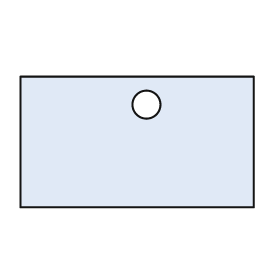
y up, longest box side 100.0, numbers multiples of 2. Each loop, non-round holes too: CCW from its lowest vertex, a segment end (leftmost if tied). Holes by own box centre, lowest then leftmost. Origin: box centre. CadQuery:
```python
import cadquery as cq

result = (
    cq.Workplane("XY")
    .moveTo(-50.0, -28.0)
    .lineTo(50.0, -28.0)
    .lineTo(50.0, 28.0)
    .lineTo(-50.0, 28.0)
    .close()
    .moveTo(4.0, 16.0)
    .circle(6.0)
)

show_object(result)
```